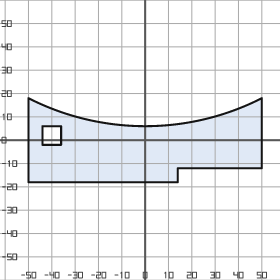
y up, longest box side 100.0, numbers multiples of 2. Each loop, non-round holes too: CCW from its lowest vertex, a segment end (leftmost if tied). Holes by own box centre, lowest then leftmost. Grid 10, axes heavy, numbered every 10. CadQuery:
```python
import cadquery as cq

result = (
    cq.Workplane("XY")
    .moveTo(-50.0, -18.0)
    .lineTo(14.0, -18.0)
    .lineTo(14.0, -12.0)
    .lineTo(50.0, -12.0)
    .lineTo(50.0, 18.0)
    .threePointArc((0.0, 6.0), (-50.0, 18.0))
    .close()
    .moveTo(-44.0, -2.0)
    .lineTo(-36.0, -2.0)
    .lineTo(-36.0, 6.0)
    .lineTo(-44.0, 6.0)
    .close()
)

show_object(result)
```